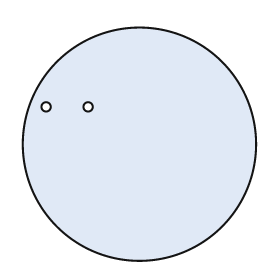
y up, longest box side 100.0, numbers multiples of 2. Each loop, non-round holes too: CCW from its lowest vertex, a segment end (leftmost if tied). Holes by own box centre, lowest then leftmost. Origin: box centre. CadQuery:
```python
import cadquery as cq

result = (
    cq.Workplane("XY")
    .moveTo(0.0, 0.0)
    .circle(50.0)
    .moveTo(-40.0, 16.0)
    .circle(2.0)
    .moveTo(-22.0, 16.0)
    .circle(2.0)
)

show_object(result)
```